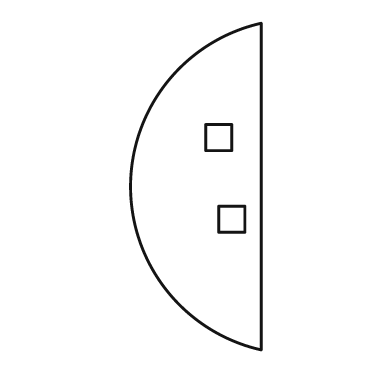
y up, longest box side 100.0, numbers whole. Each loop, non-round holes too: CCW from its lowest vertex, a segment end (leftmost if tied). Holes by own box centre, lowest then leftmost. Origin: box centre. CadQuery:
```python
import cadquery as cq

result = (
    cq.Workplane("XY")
    .moveTo(20.0, -50.0)
    .lineTo(20.0, 50.0)
    .threePointArc((-20.0, 0.0), (20.0, -50.0))
    .close()
    .moveTo(7.0, -14.0)
    .lineTo(15.0, -14.0)
    .lineTo(15.0, -6.0)
    .lineTo(7.0, -6.0)
    .close()
    .moveTo(3.0, 11.0)
    .lineTo(11.0, 11.0)
    .lineTo(11.0, 19.0)
    .lineTo(3.0, 19.0)
    .close()
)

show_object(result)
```